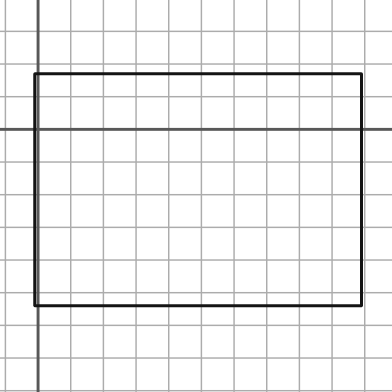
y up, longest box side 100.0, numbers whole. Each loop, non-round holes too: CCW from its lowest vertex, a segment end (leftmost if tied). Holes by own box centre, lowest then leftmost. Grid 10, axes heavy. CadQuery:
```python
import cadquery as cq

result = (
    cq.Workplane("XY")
    .moveTo(-1.0, -54.0)
    .lineTo(99.0, -54.0)
    .lineTo(99.0, 17.0)
    .lineTo(-1.0, 17.0)
    .close()
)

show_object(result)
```